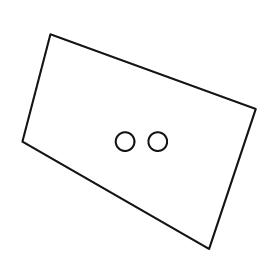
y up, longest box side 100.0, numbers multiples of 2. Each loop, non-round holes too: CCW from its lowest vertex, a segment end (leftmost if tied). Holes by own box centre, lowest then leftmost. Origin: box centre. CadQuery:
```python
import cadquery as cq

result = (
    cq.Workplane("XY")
    .moveTo(30.0, -46.0)
    .lineTo(50.0, 14.0)
    .lineTo(-38.0, 46.0)
    .lineTo(-50.0, 0.0)
    .close()
    .moveTo(-6.0, 0.0)
    .circle(4.0)
    .moveTo(8.0, 0.0)
    .circle(4.0)
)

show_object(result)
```